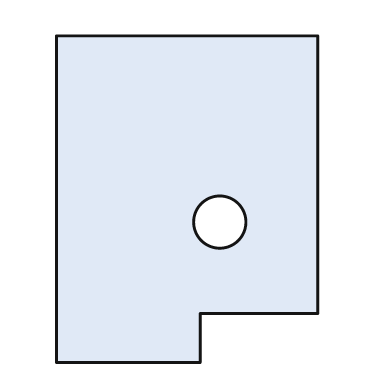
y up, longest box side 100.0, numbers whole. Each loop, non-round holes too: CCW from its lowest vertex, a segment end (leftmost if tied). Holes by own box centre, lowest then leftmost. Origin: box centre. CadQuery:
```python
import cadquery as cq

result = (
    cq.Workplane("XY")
    .moveTo(-40.0, -50.0)
    .lineTo(4.0, -50.0)
    .lineTo(4.0, -35.0)
    .lineTo(40.0, -35.0)
    .lineTo(40.0, 50.0)
    .lineTo(-40.0, 50.0)
    .close()
    .moveTo(10.0, -7.0)
    .circle(8.0)
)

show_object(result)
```